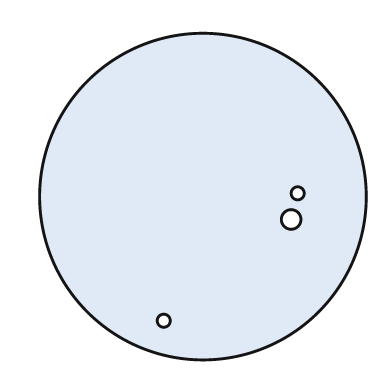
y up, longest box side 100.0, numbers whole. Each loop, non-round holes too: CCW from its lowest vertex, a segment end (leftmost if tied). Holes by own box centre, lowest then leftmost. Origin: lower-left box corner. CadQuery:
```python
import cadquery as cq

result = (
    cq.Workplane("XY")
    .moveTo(50.0, 50.0)
    .circle(50.0)
    .moveTo(38.0, 12.0)
    .circle(2.0)
    .moveTo(77.0, 43.0)
    .circle(3.0)
    .moveTo(79.0, 51.0)
    .circle(2.0)
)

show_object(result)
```